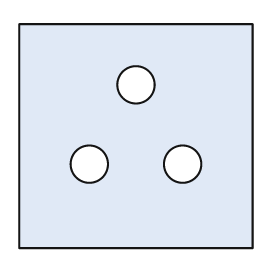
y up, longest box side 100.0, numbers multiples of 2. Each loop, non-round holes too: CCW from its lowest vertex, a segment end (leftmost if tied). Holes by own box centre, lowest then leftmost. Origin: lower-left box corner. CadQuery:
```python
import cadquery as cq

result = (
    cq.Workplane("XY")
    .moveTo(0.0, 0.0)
    .lineTo(100.0, 0.0)
    .lineTo(100.0, 96.0)
    .lineTo(0.0, 96.0)
    .close()
    .moveTo(30.0, 36.0)
    .circle(8.0)
    .moveTo(70.0, 36.0)
    .circle(8.0)
    .moveTo(50.0, 70.0)
    .circle(8.0)
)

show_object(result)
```